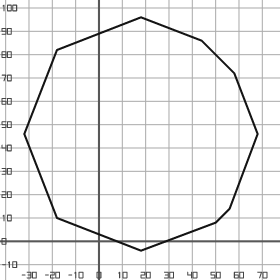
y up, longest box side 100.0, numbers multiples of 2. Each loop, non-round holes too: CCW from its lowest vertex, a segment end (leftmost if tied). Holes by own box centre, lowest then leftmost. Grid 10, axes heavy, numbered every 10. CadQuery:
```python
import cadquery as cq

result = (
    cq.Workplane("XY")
    .moveTo(18.0, -4.0)
    .lineTo(50.0, 8.0)
    .lineTo(56.0, 14.0)
    .lineTo(68.0, 46.0)
    .lineTo(58.0, 72.0)
    .lineTo(44.0, 86.0)
    .lineTo(18.0, 96.0)
    .lineTo(-18.0, 82.0)
    .lineTo(-32.0, 46.0)
    .lineTo(-18.0, 10.0)
    .close()
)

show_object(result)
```